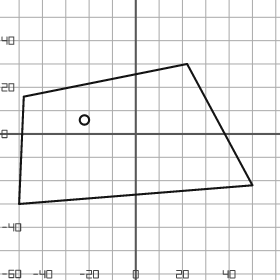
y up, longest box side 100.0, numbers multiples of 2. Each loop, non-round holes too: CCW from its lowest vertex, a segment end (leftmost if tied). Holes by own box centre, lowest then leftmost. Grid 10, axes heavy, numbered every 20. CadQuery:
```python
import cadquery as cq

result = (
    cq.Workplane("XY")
    .moveTo(-50.0, -30.0)
    .lineTo(50.0, -22.0)
    .lineTo(22.0, 30.0)
    .lineTo(-48.0, 16.0)
    .close()
    .moveTo(-22.0, 6.0)
    .circle(2.0)
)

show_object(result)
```